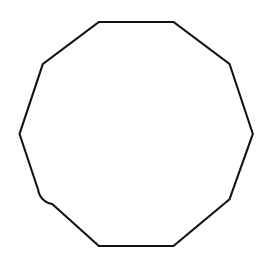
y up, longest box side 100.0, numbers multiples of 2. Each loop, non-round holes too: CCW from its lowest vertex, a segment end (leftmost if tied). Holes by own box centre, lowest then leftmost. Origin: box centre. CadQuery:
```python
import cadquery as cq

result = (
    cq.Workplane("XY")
    .moveTo(-16.0, -48.0)
    .lineTo(16.0, -48.0)
    .lineTo(40.0, -28.0)
    .lineTo(50.0, 0.0)
    .lineTo(40.0, 30.0)
    .lineTo(16.0, 48.0)
    .lineTo(-16.0, 48.0)
    .lineTo(-40.0, 30.0)
    .lineTo(-50.0, 0.0)
    .lineTo(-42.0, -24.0)
    .threePointArc((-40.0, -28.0), (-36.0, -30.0))
    .close()
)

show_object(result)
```